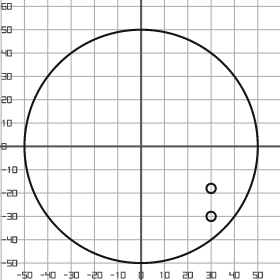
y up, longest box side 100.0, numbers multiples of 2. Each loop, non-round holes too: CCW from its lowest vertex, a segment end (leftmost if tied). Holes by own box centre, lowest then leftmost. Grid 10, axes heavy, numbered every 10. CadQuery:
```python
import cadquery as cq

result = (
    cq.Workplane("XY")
    .moveTo(0.0, 0.0)
    .circle(50.0)
    .moveTo(30.0, -30.0)
    .circle(2.0)
    .moveTo(30.0, -18.0)
    .circle(2.0)
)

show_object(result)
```